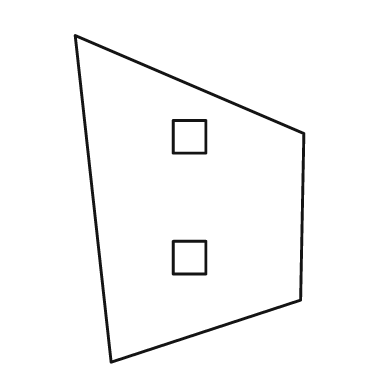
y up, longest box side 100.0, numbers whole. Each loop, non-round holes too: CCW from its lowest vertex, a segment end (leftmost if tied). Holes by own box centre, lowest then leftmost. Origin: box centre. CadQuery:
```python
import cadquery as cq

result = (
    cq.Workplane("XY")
    .moveTo(-24.0, -50.0)
    .lineTo(34.0, -31.0)
    .lineTo(35.0, 20.0)
    .lineTo(-35.0, 50.0)
    .close()
    .moveTo(-5.0, -23.0)
    .lineTo(5.0, -23.0)
    .lineTo(5.0, -13.0)
    .lineTo(-5.0, -13.0)
    .close()
    .moveTo(-5.0, 14.0)
    .lineTo(5.0, 14.0)
    .lineTo(5.0, 24.0)
    .lineTo(-5.0, 24.0)
    .close()
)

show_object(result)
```